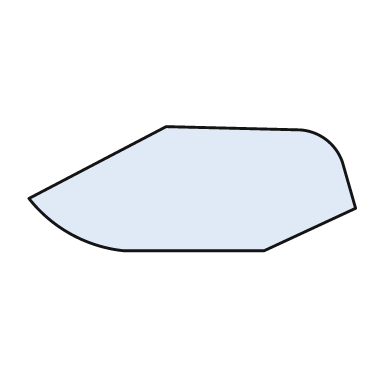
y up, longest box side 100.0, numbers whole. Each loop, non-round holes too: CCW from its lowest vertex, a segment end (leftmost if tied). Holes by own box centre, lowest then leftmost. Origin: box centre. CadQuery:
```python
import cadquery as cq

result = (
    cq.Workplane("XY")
    .moveTo(-21.0, -19.0)
    .lineTo(22.0, -19.0)
    .lineTo(50.0, -6.0)
    .lineTo(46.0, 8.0)
    .threePointArc((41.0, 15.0), (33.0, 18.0))
    .lineTo(-8.0, 19.0)
    .lineTo(-50.0, -3.0)
    .threePointArc((-37.0, -14.0), (-21.0, -19.0))
    .close()
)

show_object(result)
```